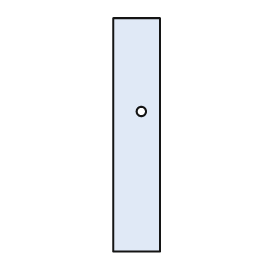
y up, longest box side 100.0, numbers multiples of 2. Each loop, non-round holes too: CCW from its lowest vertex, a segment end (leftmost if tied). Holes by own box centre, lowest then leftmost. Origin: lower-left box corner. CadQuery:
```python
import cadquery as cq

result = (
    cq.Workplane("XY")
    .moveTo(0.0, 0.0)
    .lineTo(20.0, 0.0)
    .lineTo(20.0, 100.0)
    .lineTo(0.0, 100.0)
    .close()
    .moveTo(12.0, 60.0)
    .circle(2.0)
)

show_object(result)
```